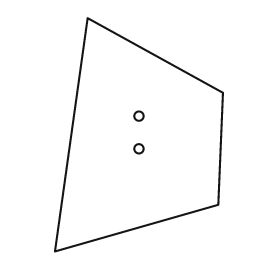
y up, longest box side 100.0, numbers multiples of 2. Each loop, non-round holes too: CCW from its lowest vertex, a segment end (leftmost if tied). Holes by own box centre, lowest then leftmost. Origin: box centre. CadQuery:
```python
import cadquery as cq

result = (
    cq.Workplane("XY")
    .moveTo(-36.0, -50.0)
    .lineTo(34.0, -30.0)
    .lineTo(36.0, 18.0)
    .lineTo(-22.0, 50.0)
    .close()
    .moveTo(0.0, -6.0)
    .circle(2.0)
    .moveTo(0.0, 8.0)
    .circle(2.0)
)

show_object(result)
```